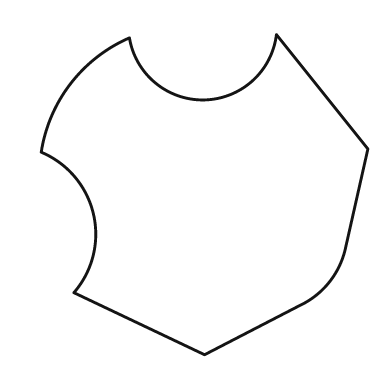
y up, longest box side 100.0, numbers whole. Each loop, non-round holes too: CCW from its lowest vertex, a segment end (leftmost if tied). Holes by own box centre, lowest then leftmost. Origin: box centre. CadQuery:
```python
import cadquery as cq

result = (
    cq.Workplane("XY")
    .moveTo(0.0, -49.0)
    .lineTo(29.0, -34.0)
    .threePointArc((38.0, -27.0), (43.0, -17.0))
    .lineTo(50.0, 14.0)
    .lineTo(22.0, 49.0)
    .threePointArc((0.0, 29.0), (-23.0, 48.0))
    .threePointArc((-41.0, 34.0), (-50.0, 13.0))
    .threePointArc((-34.0, -6.0), (-40.0, -30.0))
    .close()
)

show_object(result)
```